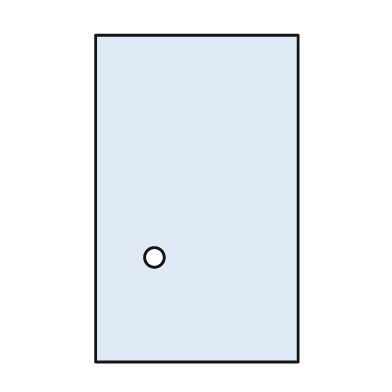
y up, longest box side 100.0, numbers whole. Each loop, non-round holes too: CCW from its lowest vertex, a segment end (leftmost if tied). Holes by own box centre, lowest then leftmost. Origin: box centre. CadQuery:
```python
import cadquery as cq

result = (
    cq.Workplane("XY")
    .moveTo(-31.0, -50.0)
    .lineTo(31.0, -50.0)
    .lineTo(31.0, 50.0)
    .lineTo(-31.0, 50.0)
    .close()
    .moveTo(-13.0, -18.0)
    .circle(3.0)
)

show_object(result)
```